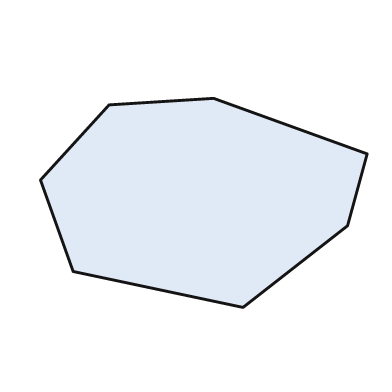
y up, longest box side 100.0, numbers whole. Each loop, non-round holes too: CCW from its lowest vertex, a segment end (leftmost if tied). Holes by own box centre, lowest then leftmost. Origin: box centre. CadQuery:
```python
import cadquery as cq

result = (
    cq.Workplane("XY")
    .moveTo(12.0, -32.0)
    .lineTo(44.0, -7.0)
    .lineTo(50.0, 15.0)
    .lineTo(3.0, 32.0)
    .lineTo(-29.0, 30.0)
    .lineTo(-50.0, 7.0)
    .lineTo(-40.0, -21.0)
    .close()
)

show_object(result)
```